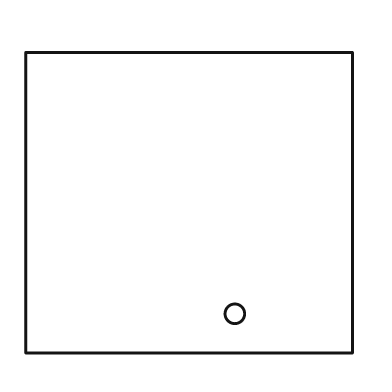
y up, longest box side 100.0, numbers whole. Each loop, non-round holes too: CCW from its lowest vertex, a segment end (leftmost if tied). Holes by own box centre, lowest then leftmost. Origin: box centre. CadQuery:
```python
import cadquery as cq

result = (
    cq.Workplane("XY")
    .moveTo(-50.0, -46.0)
    .lineTo(50.0, -46.0)
    .lineTo(50.0, 46.0)
    .lineTo(-50.0, 46.0)
    .close()
    .moveTo(14.0, -34.0)
    .circle(3.0)
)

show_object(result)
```